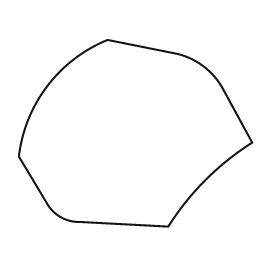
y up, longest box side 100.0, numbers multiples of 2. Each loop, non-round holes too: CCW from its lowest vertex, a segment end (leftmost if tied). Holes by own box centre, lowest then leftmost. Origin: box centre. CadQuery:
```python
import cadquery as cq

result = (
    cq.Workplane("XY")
    .moveTo(14.0, -40.0)
    .threePointArc((30.0, -20.0), (50.0, -4.0))
    .lineTo(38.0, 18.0)
    .threePointArc((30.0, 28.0), (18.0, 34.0))
    .lineTo(-12.0, 40.0)
    .threePointArc((-38.0, 20.0), (-50.0, -10.0))
    .lineTo(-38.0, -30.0)
    .threePointArc((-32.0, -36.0), (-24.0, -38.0))
    .close()
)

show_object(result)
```